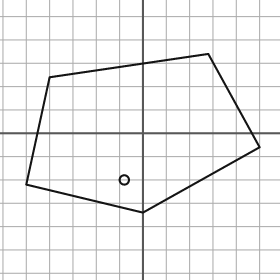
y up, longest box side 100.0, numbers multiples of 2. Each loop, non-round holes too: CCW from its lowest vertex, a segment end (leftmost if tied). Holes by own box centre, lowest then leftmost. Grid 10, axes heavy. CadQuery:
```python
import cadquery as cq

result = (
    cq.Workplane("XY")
    .moveTo(0.0, -34.0)
    .lineTo(50.0, -6.0)
    .lineTo(28.0, 34.0)
    .lineTo(-40.0, 24.0)
    .lineTo(-50.0, -22.0)
    .close()
    .moveTo(-8.0, -20.0)
    .circle(2.0)
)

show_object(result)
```